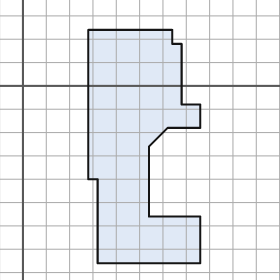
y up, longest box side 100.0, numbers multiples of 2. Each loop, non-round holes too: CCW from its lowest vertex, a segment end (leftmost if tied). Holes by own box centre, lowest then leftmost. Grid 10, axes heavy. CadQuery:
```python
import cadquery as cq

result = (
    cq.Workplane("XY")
    .moveTo(32.0, -76.0)
    .lineTo(76.0, -76.0)
    .lineTo(76.0, -56.0)
    .lineTo(54.0, -56.0)
    .lineTo(54.0, -26.0)
    .lineTo(62.0, -18.0)
    .lineTo(76.0, -18.0)
    .lineTo(76.0, -8.0)
    .lineTo(68.0, -8.0)
    .lineTo(68.0, 18.0)
    .lineTo(64.0, 18.0)
    .lineTo(64.0, 24.0)
    .lineTo(28.0, 24.0)
    .lineTo(28.0, -40.0)
    .lineTo(32.0, -40.0)
    .close()
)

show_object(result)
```